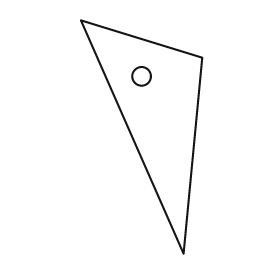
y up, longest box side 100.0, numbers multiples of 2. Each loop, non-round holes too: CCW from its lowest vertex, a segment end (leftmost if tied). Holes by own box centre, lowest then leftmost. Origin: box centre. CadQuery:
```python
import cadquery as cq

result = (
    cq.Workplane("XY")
    .moveTo(18.0, -50.0)
    .lineTo(26.0, 34.0)
    .lineTo(-26.0, 50.0)
    .close()
    .moveTo(0.0, 26.0)
    .circle(4.0)
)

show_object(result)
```